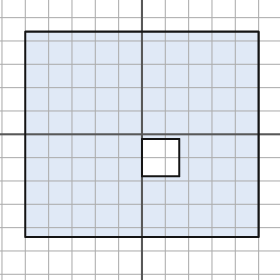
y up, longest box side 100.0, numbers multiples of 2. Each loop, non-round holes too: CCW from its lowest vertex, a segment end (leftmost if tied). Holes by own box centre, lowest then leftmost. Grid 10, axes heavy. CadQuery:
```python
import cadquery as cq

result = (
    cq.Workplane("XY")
    .moveTo(-50.0, -44.0)
    .lineTo(50.0, -44.0)
    .lineTo(50.0, 44.0)
    .lineTo(-50.0, 44.0)
    .close()
    .moveTo(0.0, -18.0)
    .lineTo(16.0, -18.0)
    .lineTo(16.0, -2.0)
    .lineTo(0.0, -2.0)
    .close()
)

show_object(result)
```